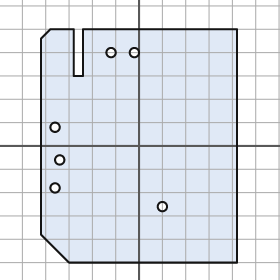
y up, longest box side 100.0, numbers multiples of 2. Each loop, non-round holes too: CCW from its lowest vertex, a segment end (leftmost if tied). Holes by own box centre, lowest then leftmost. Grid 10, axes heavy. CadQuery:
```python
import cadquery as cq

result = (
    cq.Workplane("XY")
    .moveTo(-30.0, -50.0)
    .lineTo(42.0, -50.0)
    .lineTo(42.0, 50.0)
    .lineTo(-24.0, 50.0)
    .lineTo(-24.0, 30.0)
    .lineTo(-28.0, 30.0)
    .lineTo(-28.0, 50.0)
    .lineTo(-38.0, 50.0)
    .lineTo(-42.0, 46.0)
    .lineTo(-42.0, -38.0)
    .close()
    .moveTo(10.0, -26.0)
    .circle(2.0)
    .moveTo(-36.0, -18.0)
    .circle(2.0)
    .moveTo(-34.0, -6.0)
    .circle(2.0)
    .moveTo(-36.0, 8.0)
    .circle(2.0)
    .moveTo(-12.0, 40.0)
    .circle(2.0)
    .moveTo(-2.0, 40.0)
    .circle(2.0)
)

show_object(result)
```